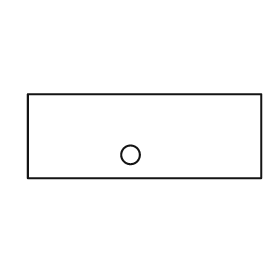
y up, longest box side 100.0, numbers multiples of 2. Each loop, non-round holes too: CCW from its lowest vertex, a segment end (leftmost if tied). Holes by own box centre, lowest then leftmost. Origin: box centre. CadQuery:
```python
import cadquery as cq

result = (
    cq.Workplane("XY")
    .moveTo(-50.0, -18.0)
    .lineTo(50.0, -18.0)
    .lineTo(50.0, 18.0)
    .lineTo(-50.0, 18.0)
    .close()
    .moveTo(-6.0, -8.0)
    .circle(4.0)
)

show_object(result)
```